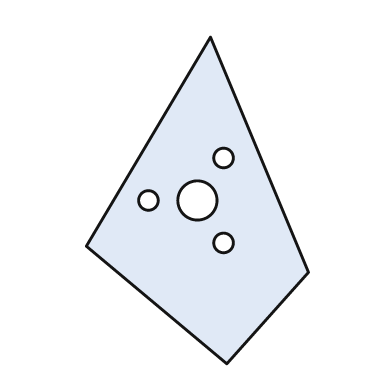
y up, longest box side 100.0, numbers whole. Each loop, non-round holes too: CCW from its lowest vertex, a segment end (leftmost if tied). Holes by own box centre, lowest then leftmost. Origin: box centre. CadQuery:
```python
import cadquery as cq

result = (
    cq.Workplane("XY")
    .moveTo(9.0, -50.0)
    .lineTo(34.0, -22.0)
    .lineTo(4.0, 50.0)
    .lineTo(-34.0, -14.0)
    .close()
    .moveTo(8.0, -13.0)
    .circle(3.0)
    .moveTo(-15.0, 0.0)
    .circle(3.0)
    .moveTo(0.0, 0.0)
    .circle(6.0)
    .moveTo(8.0, 13.0)
    .circle(3.0)
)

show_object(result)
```